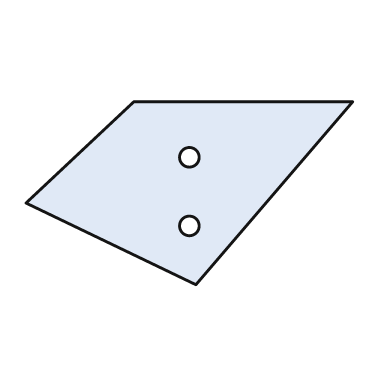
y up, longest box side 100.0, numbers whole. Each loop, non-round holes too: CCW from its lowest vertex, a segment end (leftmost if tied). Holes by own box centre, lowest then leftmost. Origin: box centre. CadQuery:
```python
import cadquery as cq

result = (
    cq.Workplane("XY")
    .moveTo(2.0, -28.0)
    .lineTo(50.0, 28.0)
    .lineTo(-17.0, 28.0)
    .lineTo(-50.0, -3.0)
    .close()
    .moveTo(0.0, -10.0)
    .circle(3.0)
    .moveTo(0.0, 11.0)
    .circle(3.0)
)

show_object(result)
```